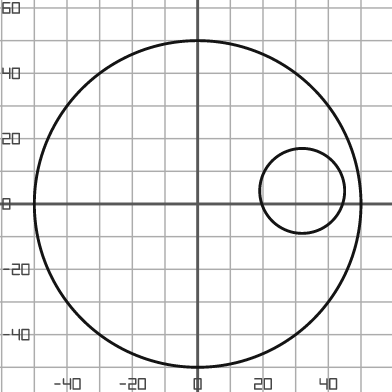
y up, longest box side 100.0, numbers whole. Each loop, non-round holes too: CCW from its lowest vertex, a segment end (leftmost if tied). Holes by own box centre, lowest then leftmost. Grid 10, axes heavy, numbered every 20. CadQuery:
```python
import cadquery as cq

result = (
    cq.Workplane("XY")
    .moveTo(0.0, 0.0)
    .circle(50.0)
    .moveTo(32.0, 4.0)
    .circle(13.0)
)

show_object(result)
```